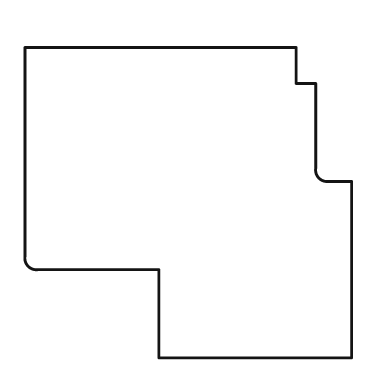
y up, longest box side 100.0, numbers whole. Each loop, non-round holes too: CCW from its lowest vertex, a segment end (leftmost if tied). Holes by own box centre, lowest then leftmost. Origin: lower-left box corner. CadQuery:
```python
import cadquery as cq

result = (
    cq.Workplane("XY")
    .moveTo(41.0, 0.0)
    .lineTo(100.0, 0.0)
    .lineTo(100.0, 54.0)
    .lineTo(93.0, 54.0)
    .threePointArc((90.0, 55.0), (89.0, 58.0))
    .lineTo(89.0, 84.0)
    .lineTo(83.0, 84.0)
    .lineTo(83.0, 95.0)
    .lineTo(0.0, 95.0)
    .lineTo(0.0, 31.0)
    .threePointArc((1.0, 28.0), (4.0, 27.0))
    .lineTo(41.0, 27.0)
    .close()
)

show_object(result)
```